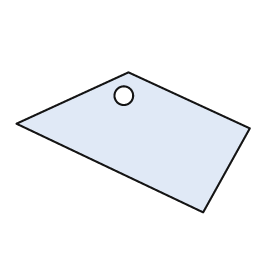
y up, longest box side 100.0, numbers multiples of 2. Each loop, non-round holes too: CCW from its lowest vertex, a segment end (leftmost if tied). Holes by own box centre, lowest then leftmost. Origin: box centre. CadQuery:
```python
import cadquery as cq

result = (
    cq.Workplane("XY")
    .moveTo(30.0, -30.0)
    .lineTo(50.0, 6.0)
    .lineTo(-2.0, 30.0)
    .lineTo(-50.0, 8.0)
    .close()
    .moveTo(-4.0, 20.0)
    .circle(4.0)
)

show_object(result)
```